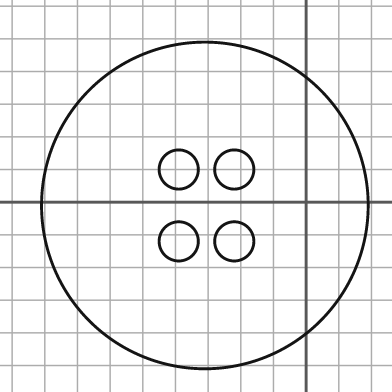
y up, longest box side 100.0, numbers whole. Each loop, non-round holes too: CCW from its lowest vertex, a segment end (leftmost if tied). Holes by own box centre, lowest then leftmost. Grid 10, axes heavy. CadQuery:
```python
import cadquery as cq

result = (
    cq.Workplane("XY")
    .moveTo(-31.0, -1.0)
    .circle(50.0)
    .moveTo(-39.0, -12.0)
    .circle(6.0)
    .moveTo(-22.0, -12.0)
    .circle(6.0)
    .moveTo(-39.0, 10.0)
    .circle(6.0)
    .moveTo(-22.0, 10.0)
    .circle(6.0)
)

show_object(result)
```